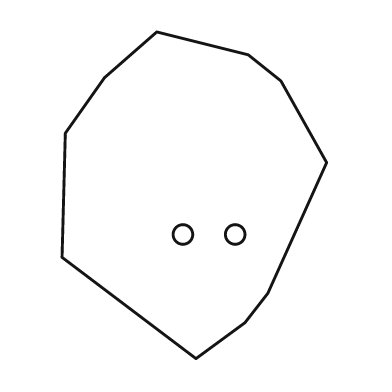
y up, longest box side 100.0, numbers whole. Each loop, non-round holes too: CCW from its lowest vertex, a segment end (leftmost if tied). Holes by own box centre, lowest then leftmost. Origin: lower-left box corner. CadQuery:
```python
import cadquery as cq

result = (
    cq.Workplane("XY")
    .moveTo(41.0, 0.0)
    .lineTo(56.0, 11.0)
    .lineTo(63.0, 20.0)
    .lineTo(81.0, 60.0)
    .lineTo(67.0, 85.0)
    .lineTo(57.0, 93.0)
    .lineTo(29.0, 100.0)
    .lineTo(13.0, 86.0)
    .lineTo(1.0, 69.0)
    .lineTo(0.0, 31.0)
    .close()
    .moveTo(37.0, 38.0)
    .circle(3.0)
    .moveTo(53.0, 38.0)
    .circle(3.0)
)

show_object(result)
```